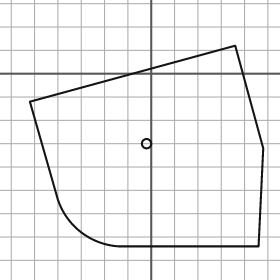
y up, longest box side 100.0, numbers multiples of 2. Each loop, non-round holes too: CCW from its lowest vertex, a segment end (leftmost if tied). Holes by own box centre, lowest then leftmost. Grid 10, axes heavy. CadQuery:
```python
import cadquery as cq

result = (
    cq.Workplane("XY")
    .moveTo(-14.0, -74.0)
    .lineTo(46.0, -74.0)
    .lineTo(48.0, -32.0)
    .lineTo(36.0, 12.0)
    .lineTo(-52.0, -12.0)
    .lineTo(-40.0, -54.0)
    .threePointArc((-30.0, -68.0), (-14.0, -74.0))
    .close()
    .moveTo(-2.0, -30.0)
    .circle(2.0)
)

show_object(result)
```